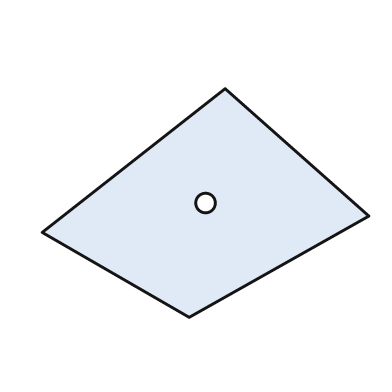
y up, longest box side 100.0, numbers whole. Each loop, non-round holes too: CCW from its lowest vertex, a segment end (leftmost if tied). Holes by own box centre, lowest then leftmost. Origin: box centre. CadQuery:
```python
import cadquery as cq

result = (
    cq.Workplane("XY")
    .moveTo(-5.0, -35.0)
    .lineTo(50.0, -4.0)
    .lineTo(6.0, 35.0)
    .lineTo(-50.0, -9.0)
    .close()
    .moveTo(0.0, 0.0)
    .circle(3.0)
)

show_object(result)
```